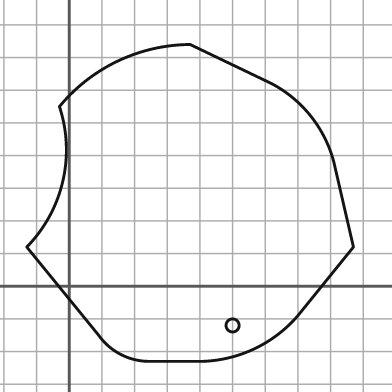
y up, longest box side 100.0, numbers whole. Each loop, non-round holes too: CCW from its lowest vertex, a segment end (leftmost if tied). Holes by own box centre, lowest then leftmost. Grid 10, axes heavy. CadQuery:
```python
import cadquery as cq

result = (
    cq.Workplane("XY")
    .moveTo(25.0, -23.0)
    .lineTo(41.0, -23.0)
    .threePointArc((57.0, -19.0), (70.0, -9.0))
    .lineTo(87.0, 12.0)
    .lineTo(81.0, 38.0)
    .threePointArc((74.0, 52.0), (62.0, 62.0))
    .lineTo(37.0, 74.0)
    .threePointArc((15.0, 69.0), (-3.0, 55.0))
    .threePointArc((-2.0, 32.0), (-13.0, 12.0))
    .lineTo(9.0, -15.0)
    .threePointArc((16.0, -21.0), (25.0, -23.0))
    .close()
    .moveTo(50.0, -12.0)
    .circle(2.0)
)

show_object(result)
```